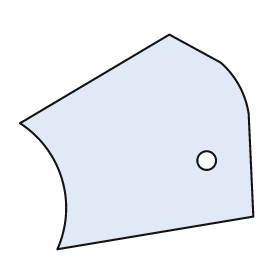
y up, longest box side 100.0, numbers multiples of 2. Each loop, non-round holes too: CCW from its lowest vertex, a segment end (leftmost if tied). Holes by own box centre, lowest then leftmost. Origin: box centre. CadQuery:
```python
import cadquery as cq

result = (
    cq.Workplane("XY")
    .moveTo(-34.0, -46.0)
    .lineTo(50.0, -32.0)
    .lineTo(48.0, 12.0)
    .threePointArc((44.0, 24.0), (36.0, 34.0))
    .lineTo(14.0, 46.0)
    .lineTo(-50.0, 8.0)
    .threePointArc((-32.0, -16.0), (-34.0, -46.0))
    .close()
    .moveTo(30.0, -8.0)
    .circle(4.0)
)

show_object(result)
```